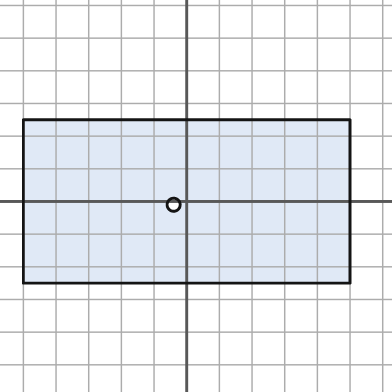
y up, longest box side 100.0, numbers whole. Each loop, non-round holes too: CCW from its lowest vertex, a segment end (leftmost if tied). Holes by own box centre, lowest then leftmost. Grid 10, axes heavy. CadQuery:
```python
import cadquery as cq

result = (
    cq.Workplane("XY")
    .moveTo(-50.0, -25.0)
    .lineTo(50.0, -25.0)
    .lineTo(50.0, 25.0)
    .lineTo(-50.0, 25.0)
    .close()
    .moveTo(-4.0, -1.0)
    .circle(2.0)
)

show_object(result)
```